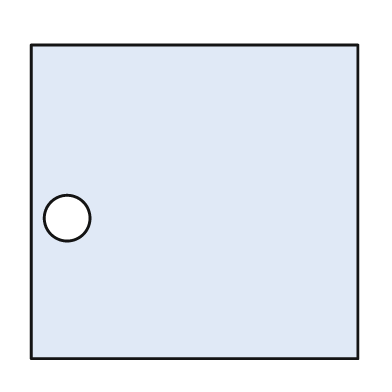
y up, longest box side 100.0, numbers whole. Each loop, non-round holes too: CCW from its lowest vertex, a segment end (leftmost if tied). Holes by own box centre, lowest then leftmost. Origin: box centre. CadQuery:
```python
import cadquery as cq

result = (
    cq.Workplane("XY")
    .moveTo(-50.0, -48.0)
    .lineTo(50.0, -48.0)
    .lineTo(50.0, 48.0)
    .lineTo(-50.0, 48.0)
    .close()
    .moveTo(-39.0, -5.0)
    .circle(7.0)
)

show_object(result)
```